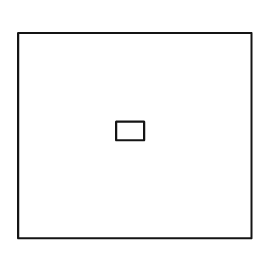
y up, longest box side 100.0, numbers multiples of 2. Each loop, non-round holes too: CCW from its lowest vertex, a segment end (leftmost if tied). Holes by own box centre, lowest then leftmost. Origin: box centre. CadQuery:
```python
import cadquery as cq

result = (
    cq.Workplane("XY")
    .moveTo(-50.0, -44.0)
    .lineTo(50.0, -44.0)
    .lineTo(50.0, 44.0)
    .lineTo(-50.0, 44.0)
    .close()
    .moveTo(-8.0, -2.0)
    .lineTo(4.0, -2.0)
    .lineTo(4.0, 6.0)
    .lineTo(-8.0, 6.0)
    .close()
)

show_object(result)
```